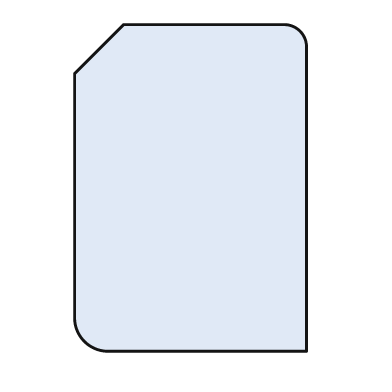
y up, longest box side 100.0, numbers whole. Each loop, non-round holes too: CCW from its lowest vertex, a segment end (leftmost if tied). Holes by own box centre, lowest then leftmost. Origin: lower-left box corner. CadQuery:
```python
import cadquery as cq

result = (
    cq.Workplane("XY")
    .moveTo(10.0, 0.0)
    .lineTo(71.0, 0.0)
    .lineTo(71.0, 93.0)
    .threePointArc((69.0, 98.0), (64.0, 100.0))
    .lineTo(15.0, 100.0)
    .lineTo(0.0, 85.0)
    .lineTo(0.0, 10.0)
    .threePointArc((3.0, 3.0), (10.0, 0.0))
    .close()
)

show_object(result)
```